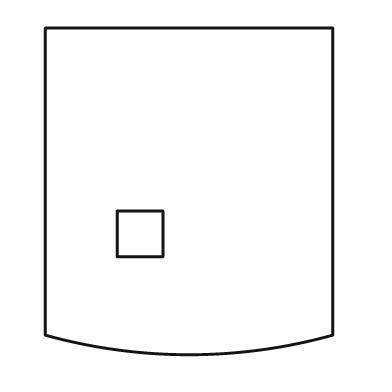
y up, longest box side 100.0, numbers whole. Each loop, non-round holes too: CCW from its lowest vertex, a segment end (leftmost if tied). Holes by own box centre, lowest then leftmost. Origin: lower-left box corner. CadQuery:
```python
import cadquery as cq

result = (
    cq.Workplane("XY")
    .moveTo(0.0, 6.0)
    .threePointArc((44.0, 0.0), (88.0, 6.0))
    .lineTo(88.0, 100.0)
    .lineTo(0.0, 100.0)
    .close()
    .moveTo(22.0, 30.0)
    .lineTo(36.0, 30.0)
    .lineTo(36.0, 44.0)
    .lineTo(22.0, 44.0)
    .close()
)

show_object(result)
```